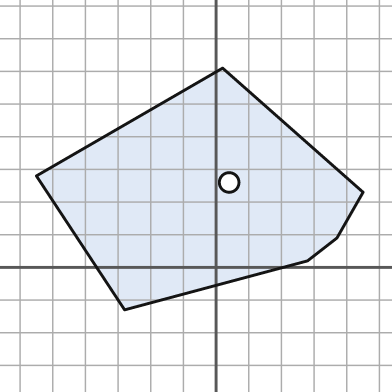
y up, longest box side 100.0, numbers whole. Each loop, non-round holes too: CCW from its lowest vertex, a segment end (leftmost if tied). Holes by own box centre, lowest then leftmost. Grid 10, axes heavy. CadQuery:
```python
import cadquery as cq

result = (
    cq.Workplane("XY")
    .moveTo(-28.0, -13.0)
    .lineTo(28.0, 2.0)
    .lineTo(37.0, 9.0)
    .lineTo(45.0, 23.0)
    .lineTo(2.0, 61.0)
    .lineTo(-55.0, 28.0)
    .close()
    .moveTo(4.0, 26.0)
    .circle(3.0)
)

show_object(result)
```